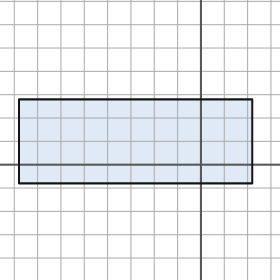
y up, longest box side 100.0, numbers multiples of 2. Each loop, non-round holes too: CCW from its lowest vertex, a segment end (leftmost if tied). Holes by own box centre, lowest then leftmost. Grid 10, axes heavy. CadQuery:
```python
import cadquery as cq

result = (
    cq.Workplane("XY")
    .moveTo(-78.0, -8.0)
    .lineTo(22.0, -8.0)
    .lineTo(22.0, 28.0)
    .lineTo(-78.0, 28.0)
    .close()
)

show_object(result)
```